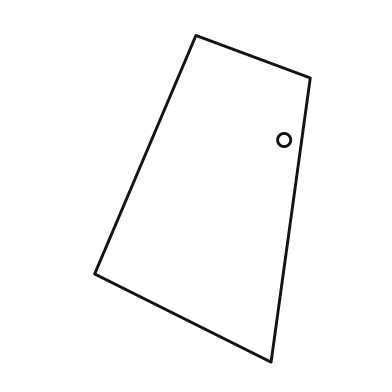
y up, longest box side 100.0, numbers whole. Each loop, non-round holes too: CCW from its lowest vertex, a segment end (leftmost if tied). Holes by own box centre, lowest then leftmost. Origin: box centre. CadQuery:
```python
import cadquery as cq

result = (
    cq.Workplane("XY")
    .moveTo(21.0, -50.0)
    .lineTo(33.0, 37.0)
    .lineTo(-2.0, 50.0)
    .lineTo(-33.0, -23.0)
    .close()
    .moveTo(25.0, 18.0)
    .circle(2.0)
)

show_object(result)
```